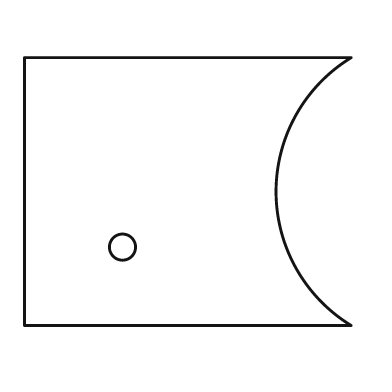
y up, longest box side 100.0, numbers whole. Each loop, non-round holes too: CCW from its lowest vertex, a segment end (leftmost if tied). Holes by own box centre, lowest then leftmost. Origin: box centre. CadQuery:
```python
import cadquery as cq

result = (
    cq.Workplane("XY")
    .moveTo(-50.0, -41.0)
    .lineTo(50.0, -41.0)
    .threePointArc((27.0, 0.0), (50.0, 41.0))
    .lineTo(-50.0, 41.0)
    .close()
    .moveTo(-20.0, -17.0)
    .circle(4.0)
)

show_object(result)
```